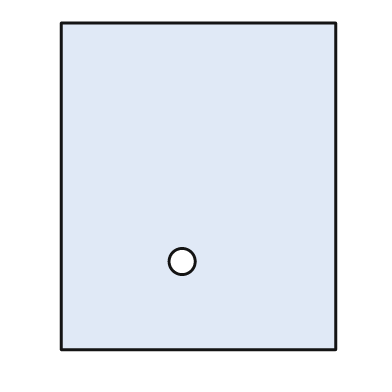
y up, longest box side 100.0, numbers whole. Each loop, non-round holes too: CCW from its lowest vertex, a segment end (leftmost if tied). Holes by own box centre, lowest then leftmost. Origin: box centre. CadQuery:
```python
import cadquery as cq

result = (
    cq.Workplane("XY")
    .moveTo(-42.0, -50.0)
    .lineTo(42.0, -50.0)
    .lineTo(42.0, 50.0)
    .lineTo(-42.0, 50.0)
    .close()
    .moveTo(-5.0, -23.0)
    .circle(4.0)
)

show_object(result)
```